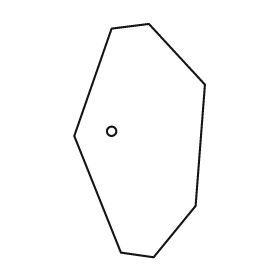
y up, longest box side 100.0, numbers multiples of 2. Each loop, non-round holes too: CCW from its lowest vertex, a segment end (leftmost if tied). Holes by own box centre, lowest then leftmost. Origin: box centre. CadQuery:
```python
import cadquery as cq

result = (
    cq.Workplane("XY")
    .moveTo(6.0, -50.0)
    .lineTo(24.0, -28.0)
    .lineTo(28.0, 24.0)
    .lineTo(4.0, 50.0)
    .lineTo(-12.0, 48.0)
    .lineTo(-28.0, 2.0)
    .lineTo(-8.0, -48.0)
    .close()
    .moveTo(-12.0, 4.0)
    .circle(2.0)
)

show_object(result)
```